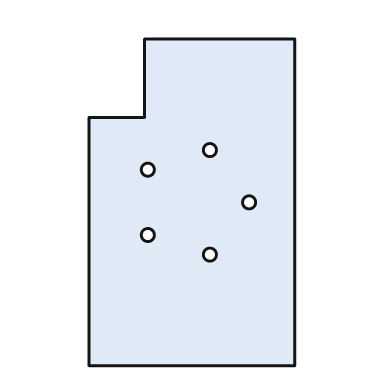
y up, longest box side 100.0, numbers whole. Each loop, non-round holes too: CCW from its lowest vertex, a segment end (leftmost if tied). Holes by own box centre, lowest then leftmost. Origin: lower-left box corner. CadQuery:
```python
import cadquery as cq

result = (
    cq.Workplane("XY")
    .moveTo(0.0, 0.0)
    .lineTo(63.0, 0.0)
    .lineTo(63.0, 100.0)
    .lineTo(17.0, 100.0)
    .lineTo(17.0, 76.0)
    .lineTo(0.0, 76.0)
    .close()
    .moveTo(37.0, 34.0)
    .circle(2.0)
    .moveTo(18.0, 40.0)
    .circle(2.0)
    .moveTo(49.0, 50.0)
    .circle(2.0)
    .moveTo(18.0, 60.0)
    .circle(2.0)
    .moveTo(37.0, 66.0)
    .circle(2.0)
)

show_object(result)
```